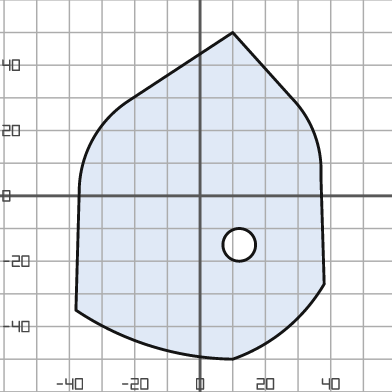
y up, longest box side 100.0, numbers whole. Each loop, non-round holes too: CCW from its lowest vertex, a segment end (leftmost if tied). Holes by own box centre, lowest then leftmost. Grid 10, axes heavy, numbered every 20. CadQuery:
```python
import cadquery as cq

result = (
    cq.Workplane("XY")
    .moveTo(10.0, -50.0)
    .threePointArc((26.0, -41.0), (38.0, -27.0))
    .lineTo(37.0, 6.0)
    .threePointArc((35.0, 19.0), (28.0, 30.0))
    .lineTo(10.0, 50.0)
    .lineTo(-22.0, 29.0)
    .threePointArc((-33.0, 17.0), (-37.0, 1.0))
    .lineTo(-38.0, -35.0)
    .threePointArc((-15.0, -46.0), (10.0, -50.0))
    .close()
    .moveTo(12.0, -15.0)
    .circle(5.0)
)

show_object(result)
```